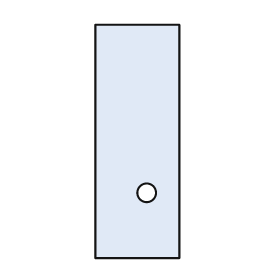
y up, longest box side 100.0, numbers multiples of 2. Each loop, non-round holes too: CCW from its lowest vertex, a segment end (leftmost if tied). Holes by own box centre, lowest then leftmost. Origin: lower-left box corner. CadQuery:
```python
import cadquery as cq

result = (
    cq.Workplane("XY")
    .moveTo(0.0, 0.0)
    .lineTo(36.0, 0.0)
    .lineTo(36.0, 100.0)
    .lineTo(0.0, 100.0)
    .close()
    .moveTo(22.0, 28.0)
    .circle(4.0)
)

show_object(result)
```